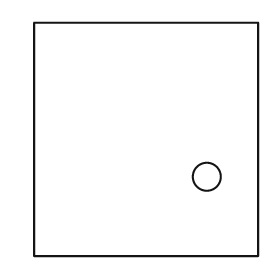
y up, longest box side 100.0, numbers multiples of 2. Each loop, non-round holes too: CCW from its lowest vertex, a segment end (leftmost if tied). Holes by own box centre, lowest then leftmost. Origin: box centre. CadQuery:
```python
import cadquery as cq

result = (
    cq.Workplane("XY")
    .moveTo(-48.0, -50.0)
    .lineTo(48.0, -50.0)
    .lineTo(48.0, 50.0)
    .lineTo(-48.0, 50.0)
    .close()
    .moveTo(26.0, -16.0)
    .circle(6.0)
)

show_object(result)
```